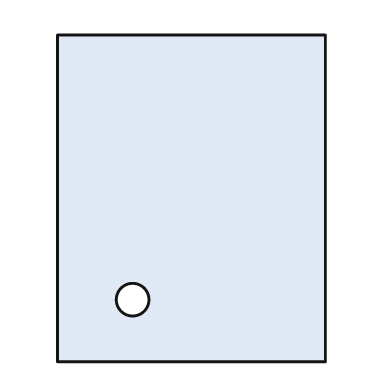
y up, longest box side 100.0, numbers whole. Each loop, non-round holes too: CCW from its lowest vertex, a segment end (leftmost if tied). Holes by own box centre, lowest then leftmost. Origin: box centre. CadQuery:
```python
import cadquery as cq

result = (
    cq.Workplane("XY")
    .moveTo(-41.0, -50.0)
    .lineTo(41.0, -50.0)
    .lineTo(41.0, 50.0)
    .lineTo(-41.0, 50.0)
    .close()
    .moveTo(-18.0, -31.0)
    .circle(5.0)
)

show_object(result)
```